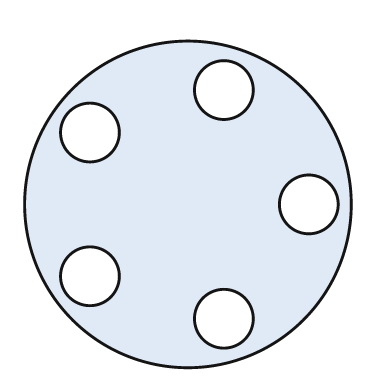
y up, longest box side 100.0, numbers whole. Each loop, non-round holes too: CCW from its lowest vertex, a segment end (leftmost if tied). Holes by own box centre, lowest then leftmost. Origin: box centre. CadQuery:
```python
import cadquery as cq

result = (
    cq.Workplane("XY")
    .moveTo(0.0, 0.0)
    .circle(50.0)
    .moveTo(11.0, -35.0)
    .circle(9.0)
    .moveTo(-30.0, -22.0)
    .circle(9.0)
    .moveTo(37.0, 0.0)
    .circle(9.0)
    .moveTo(-30.0, 22.0)
    .circle(9.0)
    .moveTo(11.0, 35.0)
    .circle(9.0)
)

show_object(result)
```